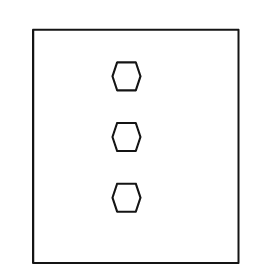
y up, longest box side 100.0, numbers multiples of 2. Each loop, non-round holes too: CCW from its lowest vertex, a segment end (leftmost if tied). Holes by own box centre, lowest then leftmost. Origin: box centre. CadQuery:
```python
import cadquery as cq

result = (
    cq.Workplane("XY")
    .moveTo(-44.0, -50.0)
    .lineTo(44.0, -50.0)
    .lineTo(44.0, 50.0)
    .lineTo(-44.0, 50.0)
    .close()
    .moveTo(-8.0, -28.0)
    .lineTo(0.0, -28.0)
    .lineTo(2.0, -22.0)
    .lineTo(0.0, -16.0)
    .lineTo(-8.0, -16.0)
    .lineTo(-10.0, -22.0)
    .close()
    .moveTo(-8.0, -2.0)
    .lineTo(0.0, -2.0)
    .lineTo(2.0, 4.0)
    .lineTo(0.0, 10.0)
    .lineTo(-8.0, 10.0)
    .lineTo(-10.0, 4.0)
    .close()
    .moveTo(-8.0, 24.0)
    .lineTo(0.0, 24.0)
    .lineTo(2.0, 30.0)
    .lineTo(0.0, 36.0)
    .lineTo(-8.0, 36.0)
    .lineTo(-10.0, 30.0)
    .close()
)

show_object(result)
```